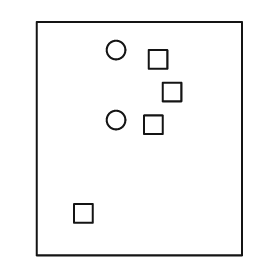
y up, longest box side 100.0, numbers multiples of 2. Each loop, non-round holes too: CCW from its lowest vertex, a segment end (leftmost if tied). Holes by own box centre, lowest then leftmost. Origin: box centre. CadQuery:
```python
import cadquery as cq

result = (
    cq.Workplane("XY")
    .moveTo(-44.0, -50.0)
    .lineTo(44.0, -50.0)
    .lineTo(44.0, 50.0)
    .lineTo(-44.0, 50.0)
    .close()
    .moveTo(-28.0, -36.0)
    .lineTo(-20.0, -36.0)
    .lineTo(-20.0, -28.0)
    .lineTo(-28.0, -28.0)
    .close()
    .moveTo(2.0, 2.0)
    .lineTo(10.0, 2.0)
    .lineTo(10.0, 10.0)
    .lineTo(2.0, 10.0)
    .close()
    .moveTo(-10.0, 8.0)
    .circle(4.0)
    .moveTo(10.0, 16.0)
    .lineTo(18.0, 16.0)
    .lineTo(18.0, 24.0)
    .lineTo(10.0, 24.0)
    .close()
    .moveTo(4.0, 30.0)
    .lineTo(12.0, 30.0)
    .lineTo(12.0, 38.0)
    .lineTo(4.0, 38.0)
    .close()
    .moveTo(-10.0, 38.0)
    .circle(4.0)
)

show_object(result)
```